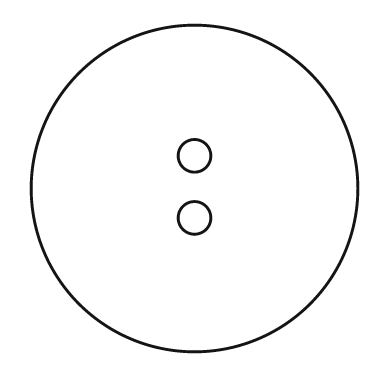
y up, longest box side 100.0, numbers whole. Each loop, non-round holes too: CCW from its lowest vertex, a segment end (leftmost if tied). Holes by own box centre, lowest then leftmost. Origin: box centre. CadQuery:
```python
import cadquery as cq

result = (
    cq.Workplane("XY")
    .moveTo(0.0, 0.0)
    .circle(50.0)
    .moveTo(0.0, -9.0)
    .circle(5.0)
    .moveTo(0.0, 10.0)
    .circle(5.0)
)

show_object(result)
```